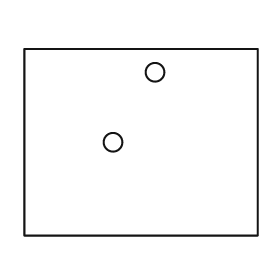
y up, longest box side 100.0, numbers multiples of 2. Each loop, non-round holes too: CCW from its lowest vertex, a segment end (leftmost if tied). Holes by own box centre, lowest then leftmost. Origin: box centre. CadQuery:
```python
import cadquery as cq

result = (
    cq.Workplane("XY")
    .moveTo(-50.0, -40.0)
    .lineTo(50.0, -40.0)
    .lineTo(50.0, 40.0)
    .lineTo(-50.0, 40.0)
    .close()
    .moveTo(-12.0, 0.0)
    .circle(4.0)
    .moveTo(6.0, 30.0)
    .circle(4.0)
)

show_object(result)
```